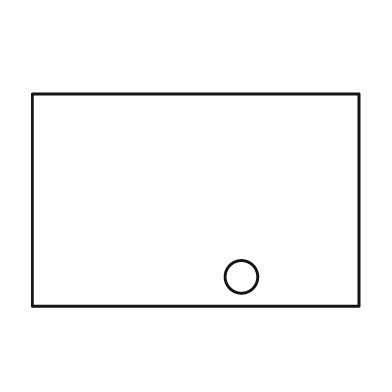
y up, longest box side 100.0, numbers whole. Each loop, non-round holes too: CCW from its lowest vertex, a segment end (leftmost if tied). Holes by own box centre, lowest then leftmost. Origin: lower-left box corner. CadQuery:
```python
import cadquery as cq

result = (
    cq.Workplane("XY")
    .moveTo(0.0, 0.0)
    .lineTo(100.0, 0.0)
    .lineTo(100.0, 65.0)
    .lineTo(0.0, 65.0)
    .close()
    .moveTo(64.0, 9.0)
    .circle(5.0)
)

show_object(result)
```